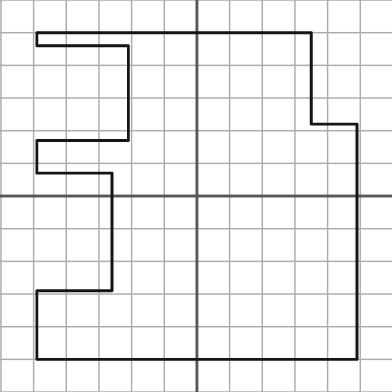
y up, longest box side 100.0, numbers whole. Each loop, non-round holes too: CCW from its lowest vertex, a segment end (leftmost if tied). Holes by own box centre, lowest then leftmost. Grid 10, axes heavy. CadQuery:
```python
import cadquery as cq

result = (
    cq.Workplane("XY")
    .moveTo(-49.0, -50.0)
    .lineTo(49.0, -50.0)
    .lineTo(49.0, 22.0)
    .lineTo(35.0, 22.0)
    .lineTo(35.0, 50.0)
    .lineTo(-49.0, 50.0)
    .lineTo(-49.0, 46.0)
    .lineTo(-21.0, 46.0)
    .lineTo(-21.0, 17.0)
    .lineTo(-49.0, 17.0)
    .lineTo(-49.0, 7.0)
    .lineTo(-26.0, 7.0)
    .lineTo(-26.0, -29.0)
    .lineTo(-49.0, -29.0)
    .close()
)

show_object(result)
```